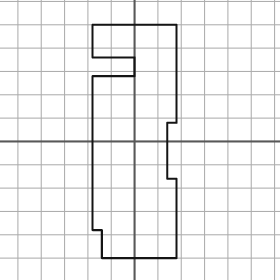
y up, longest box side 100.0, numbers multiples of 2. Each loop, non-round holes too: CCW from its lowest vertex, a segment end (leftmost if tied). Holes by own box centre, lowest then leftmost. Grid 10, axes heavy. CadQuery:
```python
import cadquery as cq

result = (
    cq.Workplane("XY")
    .moveTo(-14.0, -50.0)
    .lineTo(18.0, -50.0)
    .lineTo(18.0, -16.0)
    .lineTo(14.0, -16.0)
    .lineTo(14.0, 8.0)
    .lineTo(18.0, 8.0)
    .lineTo(18.0, 50.0)
    .lineTo(-18.0, 50.0)
    .lineTo(-18.0, 36.0)
    .lineTo(0.0, 36.0)
    .lineTo(0.0, 28.0)
    .lineTo(-18.0, 28.0)
    .lineTo(-18.0, -38.0)
    .lineTo(-14.0, -38.0)
    .close()
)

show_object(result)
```